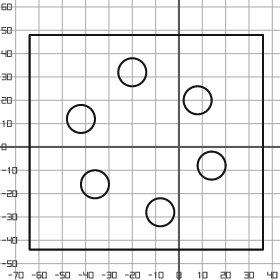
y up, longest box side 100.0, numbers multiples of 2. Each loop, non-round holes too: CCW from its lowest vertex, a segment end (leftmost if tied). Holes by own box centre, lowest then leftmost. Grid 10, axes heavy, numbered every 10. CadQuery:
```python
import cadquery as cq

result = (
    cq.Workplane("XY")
    .moveTo(-64.0, -44.0)
    .lineTo(36.0, -44.0)
    .lineTo(36.0, 48.0)
    .lineTo(-64.0, 48.0)
    .close()
    .moveTo(-8.0, -28.0)
    .circle(6.0)
    .moveTo(-36.0, -16.0)
    .circle(6.0)
    .moveTo(14.0, -8.0)
    .circle(6.0)
    .moveTo(-42.0, 12.0)
    .circle(6.0)
    .moveTo(8.0, 20.0)
    .circle(6.0)
    .moveTo(-20.0, 32.0)
    .circle(6.0)
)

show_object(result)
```